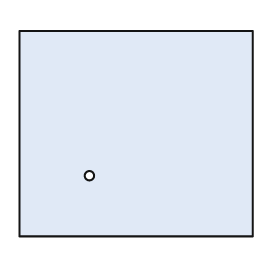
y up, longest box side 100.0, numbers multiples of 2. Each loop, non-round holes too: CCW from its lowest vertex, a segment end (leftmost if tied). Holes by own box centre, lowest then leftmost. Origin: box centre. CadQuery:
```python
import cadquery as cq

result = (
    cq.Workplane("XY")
    .moveTo(-50.0, -44.0)
    .lineTo(50.0, -44.0)
    .lineTo(50.0, 44.0)
    .lineTo(-50.0, 44.0)
    .close()
    .moveTo(-20.0, -18.0)
    .circle(2.0)
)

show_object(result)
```